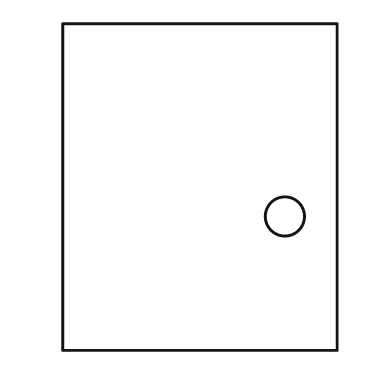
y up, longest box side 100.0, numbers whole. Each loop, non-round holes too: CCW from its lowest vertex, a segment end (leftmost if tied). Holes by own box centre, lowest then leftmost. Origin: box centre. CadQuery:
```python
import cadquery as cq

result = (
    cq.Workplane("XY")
    .moveTo(-42.0, -50.0)
    .lineTo(42.0, -50.0)
    .lineTo(42.0, 50.0)
    .lineTo(-42.0, 50.0)
    .close()
    .moveTo(26.0, -9.0)
    .circle(6.0)
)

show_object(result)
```